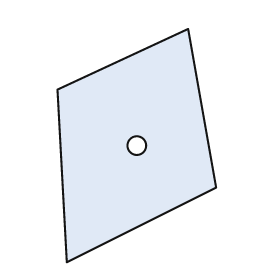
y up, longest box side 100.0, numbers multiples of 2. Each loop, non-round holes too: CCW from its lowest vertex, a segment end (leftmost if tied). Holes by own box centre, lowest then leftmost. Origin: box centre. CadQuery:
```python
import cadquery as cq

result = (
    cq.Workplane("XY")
    .moveTo(-30.0, -50.0)
    .lineTo(34.0, -18.0)
    .lineTo(22.0, 50.0)
    .lineTo(-34.0, 24.0)
    .close()
    .moveTo(0.0, 0.0)
    .circle(4.0)
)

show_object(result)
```